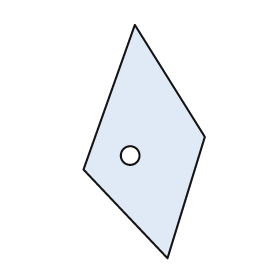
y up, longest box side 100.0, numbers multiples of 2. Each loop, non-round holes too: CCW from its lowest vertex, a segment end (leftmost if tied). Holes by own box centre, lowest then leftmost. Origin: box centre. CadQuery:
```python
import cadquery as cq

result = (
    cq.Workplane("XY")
    .moveTo(10.0, -50.0)
    .lineTo(26.0, 2.0)
    .lineTo(-4.0, 50.0)
    .lineTo(-26.0, -12.0)
    .close()
    .moveTo(-6.0, -6.0)
    .circle(4.0)
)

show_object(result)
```